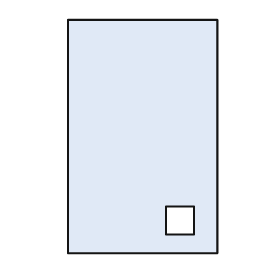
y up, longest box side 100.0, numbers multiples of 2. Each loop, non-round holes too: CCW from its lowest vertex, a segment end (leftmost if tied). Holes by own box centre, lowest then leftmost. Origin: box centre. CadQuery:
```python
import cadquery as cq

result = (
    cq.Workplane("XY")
    .moveTo(-32.0, -50.0)
    .lineTo(32.0, -50.0)
    .lineTo(32.0, 50.0)
    .lineTo(-32.0, 50.0)
    .close()
    .moveTo(10.0, -42.0)
    .lineTo(22.0, -42.0)
    .lineTo(22.0, -30.0)
    .lineTo(10.0, -30.0)
    .close()
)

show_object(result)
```